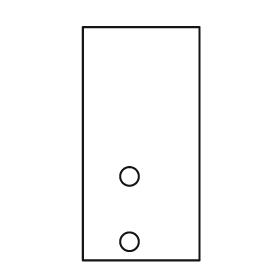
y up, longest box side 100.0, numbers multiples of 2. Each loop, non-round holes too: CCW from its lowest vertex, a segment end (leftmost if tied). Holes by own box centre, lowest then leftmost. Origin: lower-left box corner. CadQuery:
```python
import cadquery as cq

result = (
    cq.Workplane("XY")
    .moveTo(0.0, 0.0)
    .lineTo(50.0, 0.0)
    .lineTo(50.0, 100.0)
    .lineTo(0.0, 100.0)
    .close()
    .moveTo(20.0, 8.0)
    .circle(4.0)
    .moveTo(20.0, 36.0)
    .circle(4.0)
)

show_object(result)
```